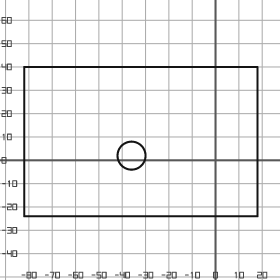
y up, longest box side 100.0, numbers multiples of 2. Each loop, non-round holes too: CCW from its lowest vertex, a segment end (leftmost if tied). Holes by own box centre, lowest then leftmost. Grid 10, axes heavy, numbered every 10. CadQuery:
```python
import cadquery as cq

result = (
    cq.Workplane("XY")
    .moveTo(-82.0, -24.0)
    .lineTo(18.0, -24.0)
    .lineTo(18.0, 40.0)
    .lineTo(-82.0, 40.0)
    .close()
    .moveTo(-36.0, 2.0)
    .circle(6.0)
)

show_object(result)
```